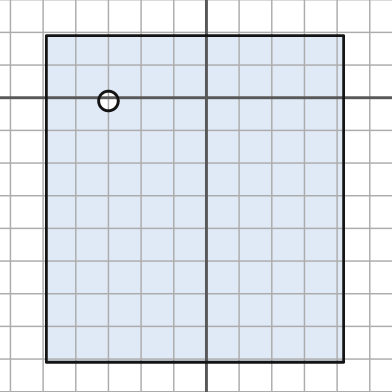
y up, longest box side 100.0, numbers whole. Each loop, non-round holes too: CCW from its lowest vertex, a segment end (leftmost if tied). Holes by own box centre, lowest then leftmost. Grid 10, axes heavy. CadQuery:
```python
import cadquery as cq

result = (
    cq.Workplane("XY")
    .moveTo(-49.0, -81.0)
    .lineTo(42.0, -81.0)
    .lineTo(42.0, 19.0)
    .lineTo(-49.0, 19.0)
    .close()
    .moveTo(-30.0, -1.0)
    .circle(3.0)
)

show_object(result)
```